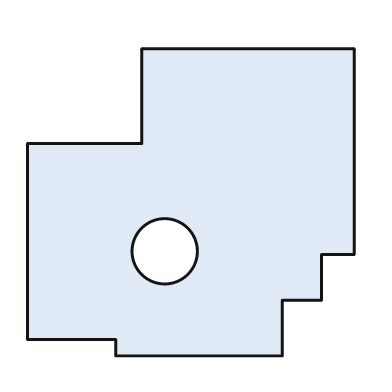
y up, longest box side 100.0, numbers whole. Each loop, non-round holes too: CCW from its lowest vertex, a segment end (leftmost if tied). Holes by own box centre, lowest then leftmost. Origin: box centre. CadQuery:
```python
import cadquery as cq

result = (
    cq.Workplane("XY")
    .moveTo(-23.0, -47.0)
    .lineTo(28.0, -47.0)
    .lineTo(28.0, -30.0)
    .lineTo(40.0, -30.0)
    .lineTo(40.0, -16.0)
    .lineTo(50.0, -16.0)
    .lineTo(50.0, 47.0)
    .lineTo(-15.0, 47.0)
    .lineTo(-15.0, 18.0)
    .lineTo(-50.0, 18.0)
    .lineTo(-50.0, -42.0)
    .lineTo(-23.0, -42.0)
    .close()
    .moveTo(-8.0, -15.0)
    .circle(10.0)
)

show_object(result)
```